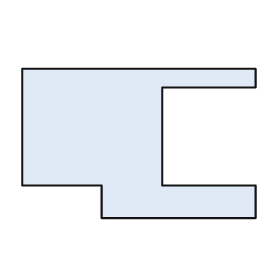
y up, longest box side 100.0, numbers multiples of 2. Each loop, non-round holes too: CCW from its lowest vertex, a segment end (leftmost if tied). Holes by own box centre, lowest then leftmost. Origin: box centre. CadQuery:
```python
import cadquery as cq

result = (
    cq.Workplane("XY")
    .moveTo(-16.0, -32.0)
    .lineTo(50.0, -32.0)
    .lineTo(50.0, -18.0)
    .lineTo(10.0, -18.0)
    .lineTo(10.0, 24.0)
    .lineTo(50.0, 24.0)
    .lineTo(50.0, 32.0)
    .lineTo(-50.0, 32.0)
    .lineTo(-50.0, -18.0)
    .lineTo(-16.0, -18.0)
    .close()
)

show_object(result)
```